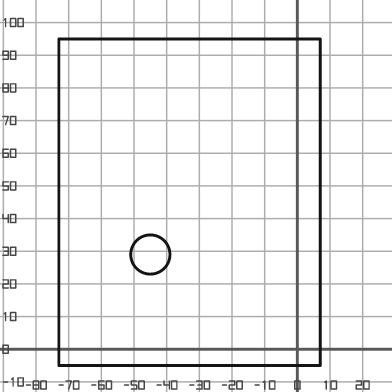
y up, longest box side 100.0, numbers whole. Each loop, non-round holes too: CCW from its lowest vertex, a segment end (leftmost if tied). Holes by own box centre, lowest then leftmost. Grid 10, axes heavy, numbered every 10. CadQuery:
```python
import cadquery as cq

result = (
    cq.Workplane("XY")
    .moveTo(-73.0, -5.0)
    .lineTo(7.0, -5.0)
    .lineTo(7.0, 95.0)
    .lineTo(-73.0, 95.0)
    .close()
    .moveTo(-45.0, 29.0)
    .circle(6.0)
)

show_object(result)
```